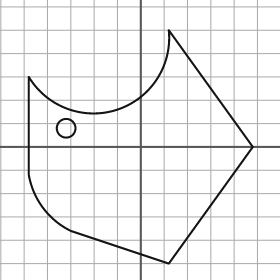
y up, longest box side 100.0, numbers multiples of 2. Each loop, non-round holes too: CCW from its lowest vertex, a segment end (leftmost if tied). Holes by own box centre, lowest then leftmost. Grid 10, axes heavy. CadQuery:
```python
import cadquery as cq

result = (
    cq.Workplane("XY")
    .moveTo(12.0, -50.0)
    .lineTo(48.0, 0.0)
    .lineTo(12.0, 50.0)
    .threePointArc((-10.0, 16.0), (-48.0, 30.0))
    .lineTo(-48.0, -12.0)
    .threePointArc((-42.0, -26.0), (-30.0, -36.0))
    .close()
    .moveTo(-32.0, 8.0)
    .circle(4.0)
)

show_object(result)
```